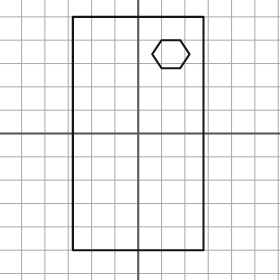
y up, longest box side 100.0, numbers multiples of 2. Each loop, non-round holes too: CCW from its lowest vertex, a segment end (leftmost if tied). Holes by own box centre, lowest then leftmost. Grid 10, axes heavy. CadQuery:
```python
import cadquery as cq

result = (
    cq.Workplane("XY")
    .moveTo(-28.0, -50.0)
    .lineTo(28.0, -50.0)
    .lineTo(28.0, 50.0)
    .lineTo(-28.0, 50.0)
    .close()
    .moveTo(10.0, 28.0)
    .lineTo(18.0, 28.0)
    .lineTo(22.0, 34.0)
    .lineTo(18.0, 40.0)
    .lineTo(10.0, 40.0)
    .lineTo(6.0, 34.0)
    .close()
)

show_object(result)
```